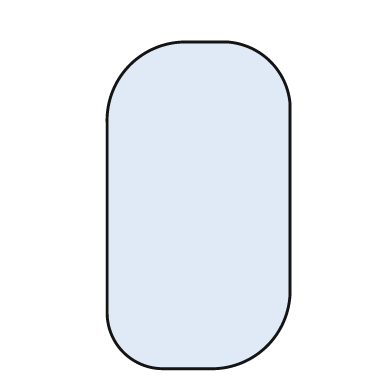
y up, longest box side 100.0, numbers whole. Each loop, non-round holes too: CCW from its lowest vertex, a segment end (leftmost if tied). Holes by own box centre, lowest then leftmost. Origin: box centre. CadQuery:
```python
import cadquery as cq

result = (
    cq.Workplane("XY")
    .moveTo(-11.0, -50.0)
    .lineTo(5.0, -50.0)
    .threePointArc((21.0, -43.0), (28.0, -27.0))
    .lineTo(28.0, 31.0)
    .threePointArc((22.0, 44.0), (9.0, 50.0))
    .lineTo(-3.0, 50.0)
    .threePointArc((-21.0, 43.0), (-28.0, 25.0))
    .lineTo(-28.0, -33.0)
    .threePointArc((-23.0, -45.0), (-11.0, -50.0))
    .close()
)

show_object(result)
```